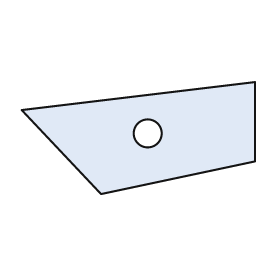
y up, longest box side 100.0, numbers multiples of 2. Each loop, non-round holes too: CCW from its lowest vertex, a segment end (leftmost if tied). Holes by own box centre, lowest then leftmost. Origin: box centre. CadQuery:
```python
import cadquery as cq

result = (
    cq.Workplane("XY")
    .moveTo(-16.0, -24.0)
    .lineTo(50.0, -10.0)
    .lineTo(50.0, 24.0)
    .lineTo(-50.0, 12.0)
    .close()
    .moveTo(4.0, 2.0)
    .circle(6.0)
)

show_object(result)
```